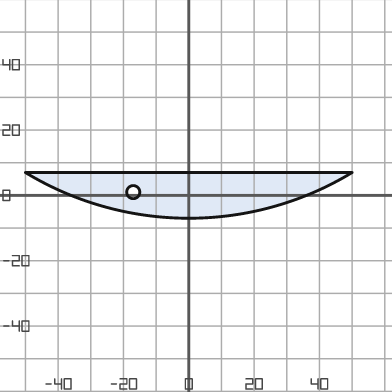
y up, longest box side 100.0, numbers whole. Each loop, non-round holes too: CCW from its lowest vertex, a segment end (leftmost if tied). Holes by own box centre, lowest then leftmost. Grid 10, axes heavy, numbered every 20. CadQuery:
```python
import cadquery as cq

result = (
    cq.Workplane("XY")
    .moveTo(-50.0, 7.0)
    .threePointArc((0.0, -7.0), (50.0, 7.0))
    .close()
    .moveTo(-17.0, 1.0)
    .circle(2.0)
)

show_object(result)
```